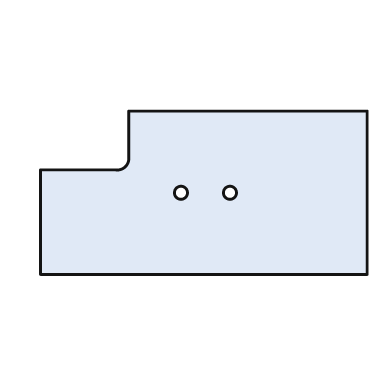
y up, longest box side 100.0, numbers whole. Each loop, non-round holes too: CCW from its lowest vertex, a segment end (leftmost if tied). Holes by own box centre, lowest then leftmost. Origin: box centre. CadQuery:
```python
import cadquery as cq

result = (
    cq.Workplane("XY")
    .moveTo(-50.0, -25.0)
    .lineTo(50.0, -25.0)
    .lineTo(50.0, 25.0)
    .lineTo(-23.0, 25.0)
    .lineTo(-23.0, 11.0)
    .threePointArc((-24.0, 8.0), (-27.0, 7.0))
    .lineTo(-50.0, 7.0)
    .close()
    .moveTo(-7.0, 0.0)
    .circle(2.0)
    .moveTo(8.0, 0.0)
    .circle(2.0)
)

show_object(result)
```